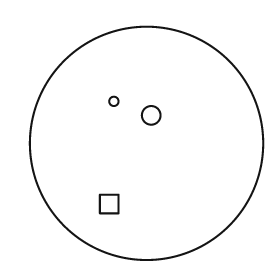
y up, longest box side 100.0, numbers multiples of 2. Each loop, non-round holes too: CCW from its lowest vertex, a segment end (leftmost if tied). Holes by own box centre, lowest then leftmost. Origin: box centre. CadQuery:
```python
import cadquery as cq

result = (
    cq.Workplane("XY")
    .moveTo(0.0, 0.0)
    .circle(50.0)
    .moveTo(-20.0, -30.0)
    .lineTo(-12.0, -30.0)
    .lineTo(-12.0, -22.0)
    .lineTo(-20.0, -22.0)
    .close()
    .moveTo(2.0, 12.0)
    .circle(4.0)
    .moveTo(-14.0, 18.0)
    .circle(2.0)
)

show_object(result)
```